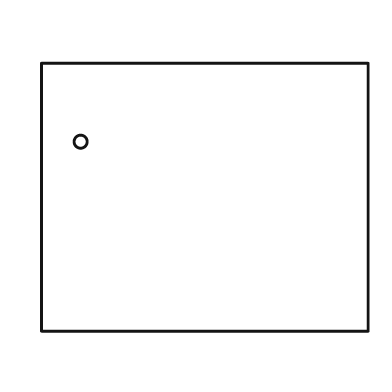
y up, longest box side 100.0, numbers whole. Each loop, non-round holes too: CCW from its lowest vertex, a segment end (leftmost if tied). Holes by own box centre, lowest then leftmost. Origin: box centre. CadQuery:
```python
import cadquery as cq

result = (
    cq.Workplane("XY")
    .moveTo(-50.0, -41.0)
    .lineTo(50.0, -41.0)
    .lineTo(50.0, 41.0)
    .lineTo(-50.0, 41.0)
    .close()
    .moveTo(-38.0, 17.0)
    .circle(2.0)
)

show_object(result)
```